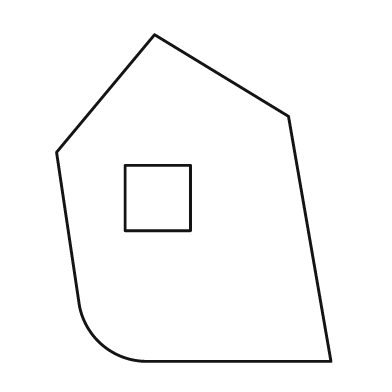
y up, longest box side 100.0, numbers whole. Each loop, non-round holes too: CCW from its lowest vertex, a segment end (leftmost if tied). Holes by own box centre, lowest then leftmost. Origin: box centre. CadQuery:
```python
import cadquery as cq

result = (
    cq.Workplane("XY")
    .moveTo(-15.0, -50.0)
    .lineTo(42.0, -50.0)
    .lineTo(29.0, 25.0)
    .lineTo(-12.0, 50.0)
    .lineTo(-42.0, 14.0)
    .lineTo(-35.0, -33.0)
    .threePointArc((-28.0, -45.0), (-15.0, -50.0))
    .close()
    .moveTo(-21.0, -10.0)
    .lineTo(-1.0, -10.0)
    .lineTo(-1.0, 10.0)
    .lineTo(-21.0, 10.0)
    .close()
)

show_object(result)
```